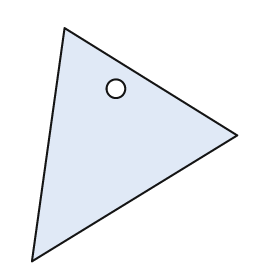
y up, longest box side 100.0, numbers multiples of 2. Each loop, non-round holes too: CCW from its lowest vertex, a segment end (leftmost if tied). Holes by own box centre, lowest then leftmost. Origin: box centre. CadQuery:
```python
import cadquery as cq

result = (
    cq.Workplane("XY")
    .moveTo(-44.0, -50.0)
    .lineTo(44.0, 4.0)
    .lineTo(-30.0, 50.0)
    .close()
    .moveTo(-8.0, 24.0)
    .circle(4.0)
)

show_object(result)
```